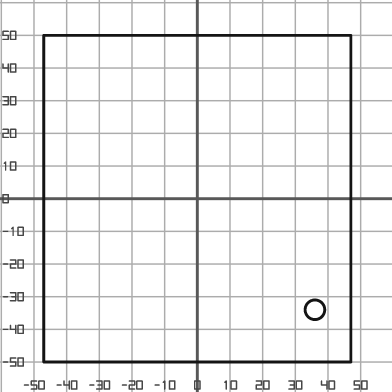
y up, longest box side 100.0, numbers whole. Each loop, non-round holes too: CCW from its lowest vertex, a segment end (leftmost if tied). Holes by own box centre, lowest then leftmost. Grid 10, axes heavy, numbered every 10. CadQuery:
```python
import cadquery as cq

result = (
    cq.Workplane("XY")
    .moveTo(-47.0, -50.0)
    .lineTo(47.0, -50.0)
    .lineTo(47.0, 50.0)
    .lineTo(-47.0, 50.0)
    .close()
    .moveTo(36.0, -34.0)
    .circle(3.0)
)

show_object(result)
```